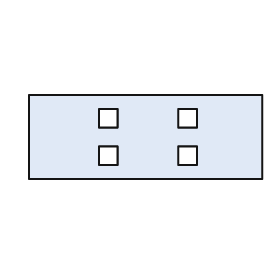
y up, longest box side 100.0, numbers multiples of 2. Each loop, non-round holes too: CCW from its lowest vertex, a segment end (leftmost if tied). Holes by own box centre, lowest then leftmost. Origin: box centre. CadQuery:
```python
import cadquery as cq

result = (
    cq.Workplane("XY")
    .moveTo(-50.0, -18.0)
    .lineTo(50.0, -18.0)
    .lineTo(50.0, 18.0)
    .lineTo(-50.0, 18.0)
    .close()
    .moveTo(-20.0, -12.0)
    .lineTo(-12.0, -12.0)
    .lineTo(-12.0, -4.0)
    .lineTo(-20.0, -4.0)
    .close()
    .moveTo(14.0, -12.0)
    .lineTo(22.0, -12.0)
    .lineTo(22.0, -4.0)
    .lineTo(14.0, -4.0)
    .close()
    .moveTo(-20.0, 4.0)
    .lineTo(-12.0, 4.0)
    .lineTo(-12.0, 12.0)
    .lineTo(-20.0, 12.0)
    .close()
    .moveTo(14.0, 4.0)
    .lineTo(22.0, 4.0)
    .lineTo(22.0, 12.0)
    .lineTo(14.0, 12.0)
    .close()
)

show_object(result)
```